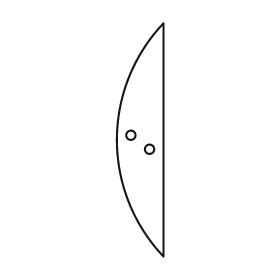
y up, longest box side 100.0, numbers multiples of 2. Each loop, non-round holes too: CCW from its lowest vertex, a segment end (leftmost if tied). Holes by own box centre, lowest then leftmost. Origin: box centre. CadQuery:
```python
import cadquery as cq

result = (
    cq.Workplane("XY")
    .moveTo(10.0, -50.0)
    .lineTo(10.0, 50.0)
    .threePointArc((-10.0, 0.0), (10.0, -50.0))
    .close()
    .moveTo(4.0, -4.0)
    .circle(2.0)
    .moveTo(-4.0, 2.0)
    .circle(2.0)
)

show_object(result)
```